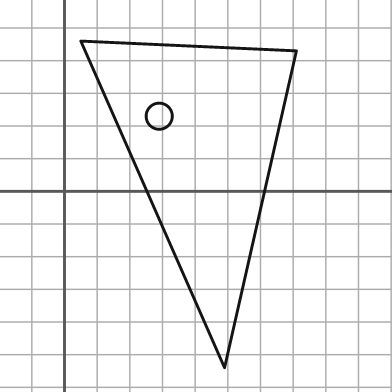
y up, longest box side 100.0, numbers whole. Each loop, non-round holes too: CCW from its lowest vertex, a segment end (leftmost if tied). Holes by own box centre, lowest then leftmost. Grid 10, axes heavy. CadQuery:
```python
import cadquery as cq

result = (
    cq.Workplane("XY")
    .moveTo(49.0, -54.0)
    .lineTo(71.0, 43.0)
    .lineTo(5.0, 46.0)
    .close()
    .moveTo(29.0, 23.0)
    .circle(4.0)
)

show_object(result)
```